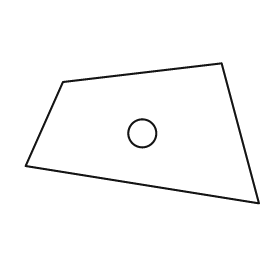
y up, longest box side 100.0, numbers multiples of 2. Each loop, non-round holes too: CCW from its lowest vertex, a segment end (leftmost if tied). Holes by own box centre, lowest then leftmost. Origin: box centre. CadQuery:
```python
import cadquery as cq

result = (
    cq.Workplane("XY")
    .moveTo(50.0, -30.0)
    .lineTo(34.0, 30.0)
    .lineTo(-34.0, 22.0)
    .lineTo(-50.0, -14.0)
    .close()
    .moveTo(0.0, 0.0)
    .circle(6.0)
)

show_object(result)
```